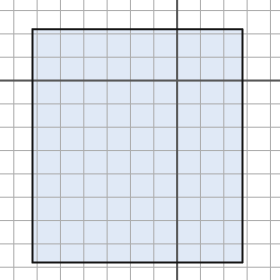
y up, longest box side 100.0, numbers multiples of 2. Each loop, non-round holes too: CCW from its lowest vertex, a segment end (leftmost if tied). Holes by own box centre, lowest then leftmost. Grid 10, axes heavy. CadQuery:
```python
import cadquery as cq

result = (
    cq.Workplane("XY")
    .moveTo(-62.0, -78.0)
    .lineTo(28.0, -78.0)
    .lineTo(28.0, 22.0)
    .lineTo(-62.0, 22.0)
    .close()
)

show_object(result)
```